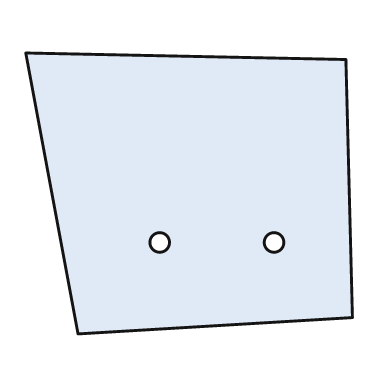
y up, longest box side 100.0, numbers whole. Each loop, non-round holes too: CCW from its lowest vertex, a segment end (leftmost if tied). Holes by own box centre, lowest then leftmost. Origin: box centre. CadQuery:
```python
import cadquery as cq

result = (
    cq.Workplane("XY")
    .moveTo(-34.0, -43.0)
    .lineTo(50.0, -38.0)
    .lineTo(48.0, 41.0)
    .lineTo(-50.0, 43.0)
    .close()
    .moveTo(-9.0, -15.0)
    .circle(3.0)
    .moveTo(26.0, -15.0)
    .circle(3.0)
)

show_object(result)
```